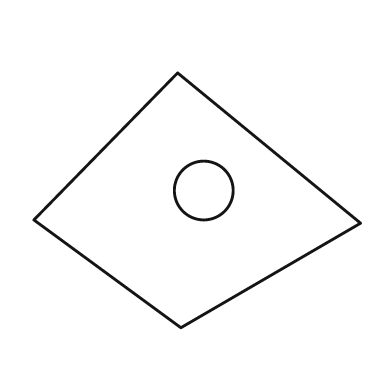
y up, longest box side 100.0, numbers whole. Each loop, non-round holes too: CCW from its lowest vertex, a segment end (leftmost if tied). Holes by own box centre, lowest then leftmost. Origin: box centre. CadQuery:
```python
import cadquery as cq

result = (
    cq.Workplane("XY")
    .moveTo(-5.0, -39.0)
    .lineTo(50.0, -7.0)
    .lineTo(-6.0, 39.0)
    .lineTo(-50.0, -6.0)
    .close()
    .moveTo(2.0, 3.0)
    .circle(9.0)
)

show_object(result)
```